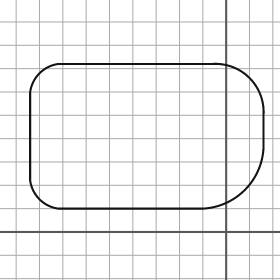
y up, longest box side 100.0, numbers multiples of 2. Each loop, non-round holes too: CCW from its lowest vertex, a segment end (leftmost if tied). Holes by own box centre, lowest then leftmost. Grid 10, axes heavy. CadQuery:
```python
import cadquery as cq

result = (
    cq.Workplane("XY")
    .moveTo(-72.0, 10.0)
    .lineTo(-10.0, 10.0)
    .threePointArc((8.0, 18.0), (16.0, 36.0))
    .lineTo(16.0, 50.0)
    .threePointArc((10.0, 66.0), (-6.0, 72.0))
    .lineTo(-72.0, 72.0)
    .threePointArc((-80.0, 68.0), (-84.0, 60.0))
    .lineTo(-84.0, 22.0)
    .threePointArc((-80.0, 14.0), (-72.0, 10.0))
    .close()
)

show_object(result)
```